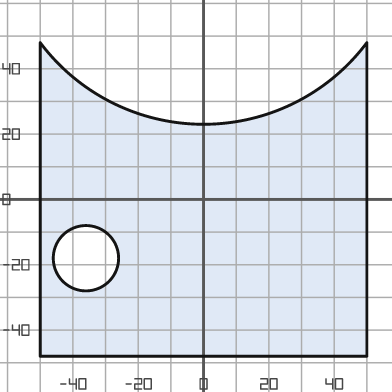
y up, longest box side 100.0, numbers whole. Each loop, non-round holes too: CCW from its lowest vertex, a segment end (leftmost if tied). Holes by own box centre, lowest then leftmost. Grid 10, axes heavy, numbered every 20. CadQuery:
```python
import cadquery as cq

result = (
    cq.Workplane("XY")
    .moveTo(-50.0, -48.0)
    .lineTo(50.0, -48.0)
    .lineTo(50.0, 48.0)
    .threePointArc((0.0, 23.0), (-50.0, 48.0))
    .close()
    .moveTo(-36.0, -18.0)
    .circle(10.0)
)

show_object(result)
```